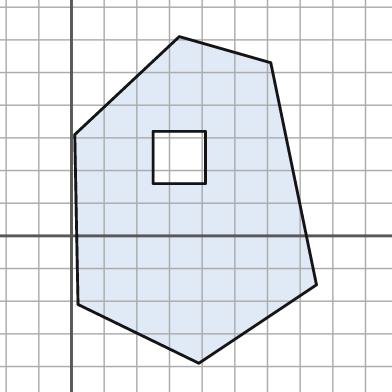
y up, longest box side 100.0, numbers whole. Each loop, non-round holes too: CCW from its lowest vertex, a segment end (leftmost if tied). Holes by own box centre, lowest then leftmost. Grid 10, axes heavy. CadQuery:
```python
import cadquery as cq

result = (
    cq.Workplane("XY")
    .moveTo(39.0, -39.0)
    .lineTo(75.0, -15.0)
    .lineTo(61.0, 53.0)
    .lineTo(33.0, 61.0)
    .lineTo(1.0, 31.0)
    .lineTo(2.0, -21.0)
    .close()
    .moveTo(25.0, 16.0)
    .lineTo(41.0, 16.0)
    .lineTo(41.0, 32.0)
    .lineTo(25.0, 32.0)
    .close()
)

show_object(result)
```